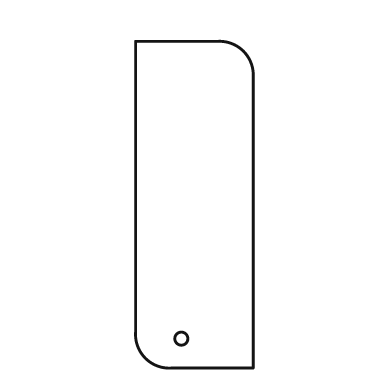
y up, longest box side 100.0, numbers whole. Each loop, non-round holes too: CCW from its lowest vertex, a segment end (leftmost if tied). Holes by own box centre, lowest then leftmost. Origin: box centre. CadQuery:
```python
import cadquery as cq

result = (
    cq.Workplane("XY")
    .moveTo(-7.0, -50.0)
    .lineTo(18.0, -50.0)
    .lineTo(18.0, 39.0)
    .threePointArc((15.0, 47.0), (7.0, 50.0))
    .lineTo(-18.0, 50.0)
    .lineTo(-18.0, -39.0)
    .threePointArc((-15.0, -47.0), (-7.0, -50.0))
    .close()
    .moveTo(-4.0, -41.0)
    .circle(2.0)
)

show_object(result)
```